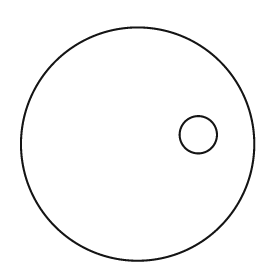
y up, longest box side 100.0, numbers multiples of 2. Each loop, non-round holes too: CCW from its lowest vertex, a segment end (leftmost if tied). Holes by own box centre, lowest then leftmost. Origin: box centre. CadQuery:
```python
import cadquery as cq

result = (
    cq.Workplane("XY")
    .moveTo(0.0, 0.0)
    .circle(50.0)
    .moveTo(26.0, 4.0)
    .circle(8.0)
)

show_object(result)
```